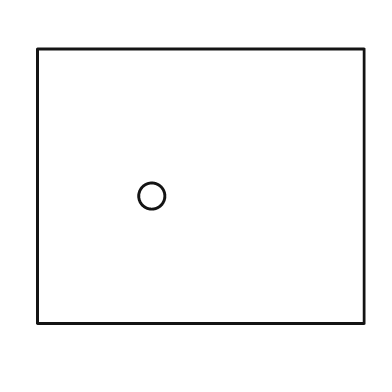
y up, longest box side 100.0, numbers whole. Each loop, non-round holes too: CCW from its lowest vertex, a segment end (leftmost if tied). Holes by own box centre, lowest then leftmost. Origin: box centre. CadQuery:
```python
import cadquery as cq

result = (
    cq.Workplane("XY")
    .moveTo(-50.0, -42.0)
    .lineTo(50.0, -42.0)
    .lineTo(50.0, 42.0)
    .lineTo(-50.0, 42.0)
    .close()
    .moveTo(-15.0, -3.0)
    .circle(4.0)
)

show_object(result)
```